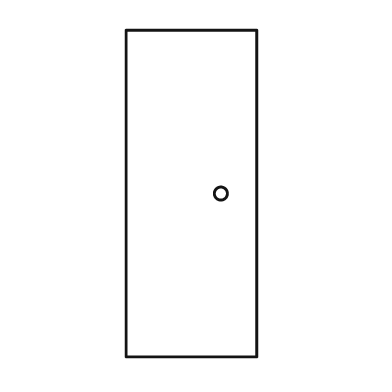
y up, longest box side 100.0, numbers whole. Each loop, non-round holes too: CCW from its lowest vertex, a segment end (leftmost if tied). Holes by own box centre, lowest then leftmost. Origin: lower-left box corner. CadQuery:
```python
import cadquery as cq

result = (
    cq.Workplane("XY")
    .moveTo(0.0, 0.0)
    .lineTo(40.0, 0.0)
    .lineTo(40.0, 100.0)
    .lineTo(0.0, 100.0)
    .close()
    .moveTo(29.0, 50.0)
    .circle(2.0)
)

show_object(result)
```